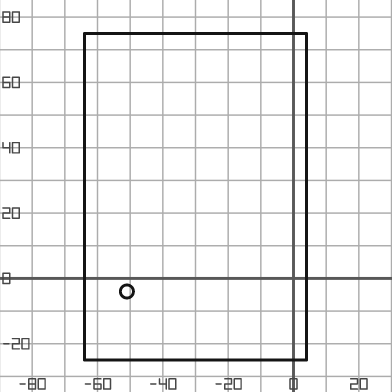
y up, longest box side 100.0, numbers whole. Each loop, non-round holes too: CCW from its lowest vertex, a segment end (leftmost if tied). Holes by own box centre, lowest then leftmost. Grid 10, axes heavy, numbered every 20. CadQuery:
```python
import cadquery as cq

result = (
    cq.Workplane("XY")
    .moveTo(-64.0, -25.0)
    .lineTo(4.0, -25.0)
    .lineTo(4.0, 75.0)
    .lineTo(-64.0, 75.0)
    .close()
    .moveTo(-51.0, -4.0)
    .circle(2.0)
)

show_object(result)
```